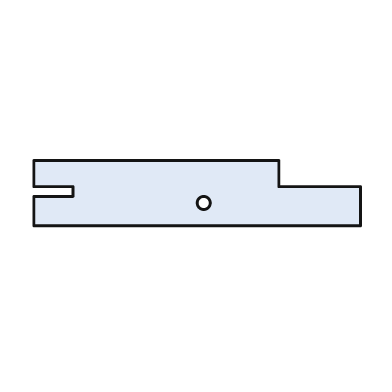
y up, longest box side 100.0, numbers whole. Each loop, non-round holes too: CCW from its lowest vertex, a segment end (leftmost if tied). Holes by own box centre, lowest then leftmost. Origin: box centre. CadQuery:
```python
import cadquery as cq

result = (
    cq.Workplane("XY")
    .moveTo(-50.0, -10.0)
    .lineTo(50.0, -10.0)
    .lineTo(50.0, 2.0)
    .lineTo(25.0, 2.0)
    .lineTo(25.0, 10.0)
    .lineTo(-50.0, 10.0)
    .lineTo(-50.0, 2.0)
    .lineTo(-38.0, 2.0)
    .lineTo(-38.0, -1.0)
    .lineTo(-50.0, -1.0)
    .close()
    .moveTo(2.0, -3.0)
    .circle(2.0)
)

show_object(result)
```